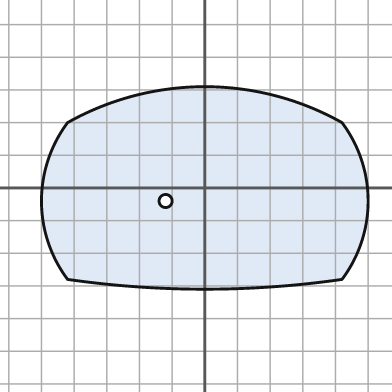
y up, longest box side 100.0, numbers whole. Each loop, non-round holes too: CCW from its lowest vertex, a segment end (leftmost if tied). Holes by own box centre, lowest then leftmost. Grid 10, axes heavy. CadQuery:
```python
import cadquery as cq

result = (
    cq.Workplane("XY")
    .moveTo(-42.0, -28.0)
    .threePointArc((0.0, -31.0), (42.0, -28.0))
    .threePointArc((50.0, -4.0), (42.0, 20.0))
    .threePointArc((0.0, 31.0), (-42.0, 20.0))
    .threePointArc((-50.0, -4.0), (-42.0, -28.0))
    .close()
    .moveTo(-12.0, -4.0)
    .circle(2.0)
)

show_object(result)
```